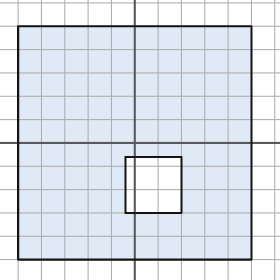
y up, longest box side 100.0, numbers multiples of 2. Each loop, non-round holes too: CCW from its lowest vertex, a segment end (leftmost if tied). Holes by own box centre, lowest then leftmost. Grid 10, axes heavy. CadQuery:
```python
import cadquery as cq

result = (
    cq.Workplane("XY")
    .moveTo(-50.0, -50.0)
    .lineTo(50.0, -50.0)
    .lineTo(50.0, 50.0)
    .lineTo(-50.0, 50.0)
    .close()
    .moveTo(-4.0, -30.0)
    .lineTo(20.0, -30.0)
    .lineTo(20.0, -6.0)
    .lineTo(-4.0, -6.0)
    .close()
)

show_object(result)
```